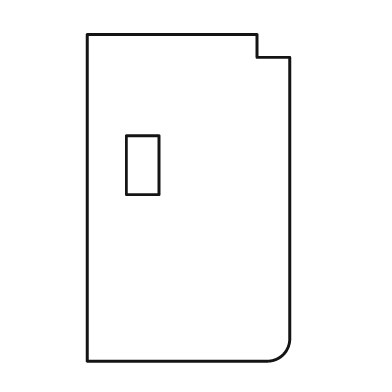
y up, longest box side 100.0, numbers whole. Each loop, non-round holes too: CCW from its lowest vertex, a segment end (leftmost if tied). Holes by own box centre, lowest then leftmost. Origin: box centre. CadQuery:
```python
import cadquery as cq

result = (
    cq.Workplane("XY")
    .moveTo(-31.0, -50.0)
    .lineTo(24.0, -50.0)
    .threePointArc((29.0, -48.0), (31.0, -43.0))
    .lineTo(31.0, 43.0)
    .lineTo(21.0, 43.0)
    .lineTo(21.0, 50.0)
    .lineTo(-31.0, 50.0)
    .close()
    .moveTo(-19.0, 1.0)
    .lineTo(-9.0, 1.0)
    .lineTo(-9.0, 19.0)
    .lineTo(-19.0, 19.0)
    .close()
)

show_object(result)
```